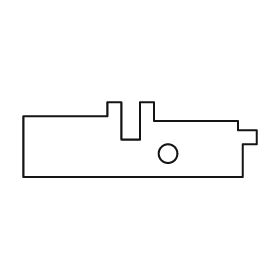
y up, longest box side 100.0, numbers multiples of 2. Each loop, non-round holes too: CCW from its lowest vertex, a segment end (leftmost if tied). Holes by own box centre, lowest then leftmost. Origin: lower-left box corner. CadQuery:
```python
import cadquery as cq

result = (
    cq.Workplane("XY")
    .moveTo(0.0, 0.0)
    .lineTo(94.0, 0.0)
    .lineTo(94.0, 14.0)
    .lineTo(100.0, 14.0)
    .lineTo(100.0, 20.0)
    .lineTo(92.0, 20.0)
    .lineTo(92.0, 24.0)
    .lineTo(56.0, 24.0)
    .lineTo(56.0, 32.0)
    .lineTo(50.0, 32.0)
    .lineTo(50.0, 16.0)
    .lineTo(42.0, 16.0)
    .lineTo(42.0, 32.0)
    .lineTo(36.0, 32.0)
    .lineTo(36.0, 26.0)
    .lineTo(0.0, 26.0)
    .close()
    .moveTo(62.0, 10.0)
    .circle(4.0)
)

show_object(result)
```